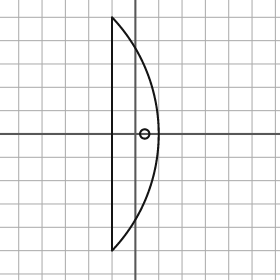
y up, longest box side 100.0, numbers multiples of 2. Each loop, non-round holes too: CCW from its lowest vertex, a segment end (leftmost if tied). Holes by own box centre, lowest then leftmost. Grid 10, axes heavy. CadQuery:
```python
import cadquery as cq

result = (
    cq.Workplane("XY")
    .moveTo(-10.0, -50.0)
    .threePointArc((10.0, 0.0), (-10.0, 50.0))
    .close()
    .moveTo(4.0, 0.0)
    .circle(2.0)
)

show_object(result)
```